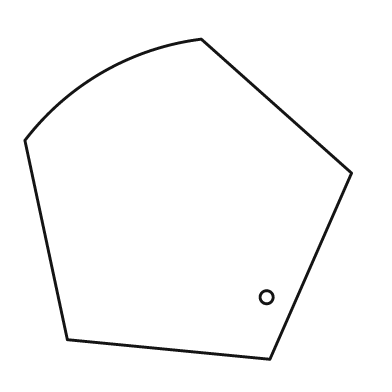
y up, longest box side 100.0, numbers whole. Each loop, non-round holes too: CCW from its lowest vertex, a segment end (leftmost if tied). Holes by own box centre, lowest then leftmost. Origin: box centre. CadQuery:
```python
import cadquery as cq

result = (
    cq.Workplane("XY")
    .moveTo(25.0, -49.0)
    .lineTo(50.0, 8.0)
    .lineTo(4.0, 49.0)
    .threePointArc((-26.0, 39.0), (-50.0, 18.0))
    .lineTo(-37.0, -43.0)
    .close()
    .moveTo(24.0, -30.0)
    .circle(2.0)
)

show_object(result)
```